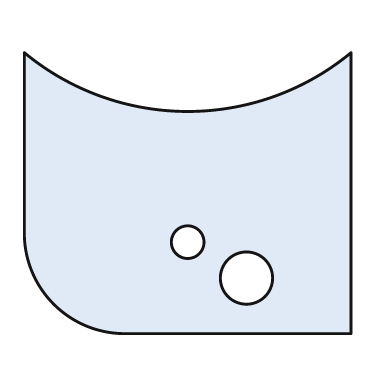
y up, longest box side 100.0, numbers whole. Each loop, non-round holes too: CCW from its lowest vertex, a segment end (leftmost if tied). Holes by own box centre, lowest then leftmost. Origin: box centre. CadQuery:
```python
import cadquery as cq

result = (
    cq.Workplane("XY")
    .moveTo(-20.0, -43.0)
    .lineTo(50.0, -43.0)
    .lineTo(50.0, 43.0)
    .threePointArc((0.0, 25.0), (-50.0, 43.0))
    .lineTo(-50.0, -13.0)
    .threePointArc((-41.0, -34.0), (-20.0, -43.0))
    .close()
    .moveTo(18.0, -26.0)
    .circle(8.0)
    .moveTo(0.0, -15.0)
    .circle(5.0)
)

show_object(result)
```